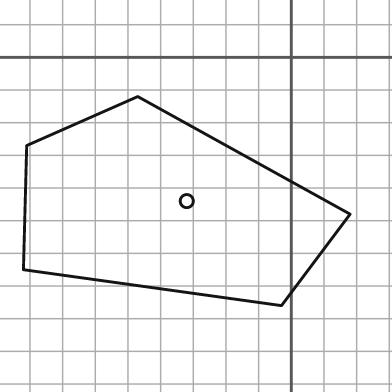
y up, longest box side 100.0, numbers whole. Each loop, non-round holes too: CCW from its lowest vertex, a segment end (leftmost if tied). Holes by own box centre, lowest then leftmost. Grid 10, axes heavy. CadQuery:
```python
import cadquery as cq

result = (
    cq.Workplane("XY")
    .moveTo(-3.0, -76.0)
    .lineTo(18.0, -48.0)
    .lineTo(-47.0, -12.0)
    .lineTo(-81.0, -27.0)
    .lineTo(-82.0, -65.0)
    .close()
    .moveTo(-32.0, -44.0)
    .circle(2.0)
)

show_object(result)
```